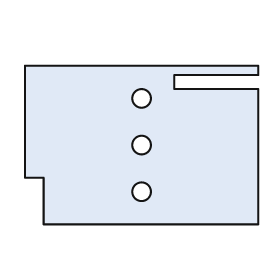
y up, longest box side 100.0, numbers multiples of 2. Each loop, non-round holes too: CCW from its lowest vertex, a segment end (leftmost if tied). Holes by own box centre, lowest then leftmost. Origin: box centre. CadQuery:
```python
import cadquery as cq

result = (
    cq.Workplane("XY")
    .moveTo(-42.0, -34.0)
    .lineTo(50.0, -34.0)
    .lineTo(50.0, 24.0)
    .lineTo(14.0, 24.0)
    .lineTo(14.0, 30.0)
    .lineTo(50.0, 30.0)
    .lineTo(50.0, 34.0)
    .lineTo(-50.0, 34.0)
    .lineTo(-50.0, -14.0)
    .lineTo(-42.0, -14.0)
    .close()
    .moveTo(0.0, -20.0)
    .circle(4.0)
    .moveTo(0.0, 0.0)
    .circle(4.0)
    .moveTo(0.0, 20.0)
    .circle(4.0)
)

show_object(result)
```